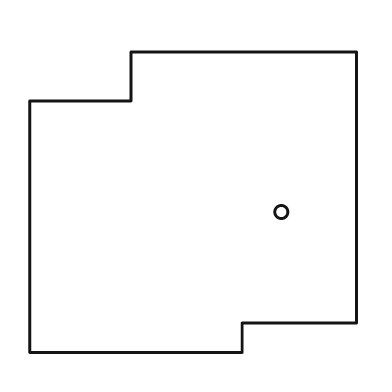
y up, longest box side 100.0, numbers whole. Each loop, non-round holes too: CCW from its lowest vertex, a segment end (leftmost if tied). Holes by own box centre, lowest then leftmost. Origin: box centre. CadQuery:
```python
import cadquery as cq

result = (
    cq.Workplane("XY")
    .moveTo(-50.0, -46.0)
    .lineTo(15.0, -46.0)
    .lineTo(15.0, -37.0)
    .lineTo(50.0, -37.0)
    .lineTo(50.0, 46.0)
    .lineTo(-19.0, 46.0)
    .lineTo(-19.0, 31.0)
    .lineTo(-50.0, 31.0)
    .close()
    .moveTo(27.0, -3.0)
    .circle(2.0)
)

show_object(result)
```